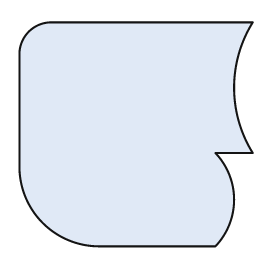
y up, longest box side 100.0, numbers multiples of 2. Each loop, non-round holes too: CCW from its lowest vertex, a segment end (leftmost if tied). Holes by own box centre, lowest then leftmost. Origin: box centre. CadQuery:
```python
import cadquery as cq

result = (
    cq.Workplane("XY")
    .moveTo(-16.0, -48.0)
    .lineTo(34.0, -48.0)
    .threePointArc((42.0, -28.0), (34.0, -8.0))
    .lineTo(50.0, -8.0)
    .threePointArc((42.0, 20.0), (50.0, 48.0))
    .lineTo(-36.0, 48.0)
    .threePointArc((-46.0, 44.0), (-50.0, 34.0))
    .lineTo(-50.0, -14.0)
    .threePointArc((-40.0, -38.0), (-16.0, -48.0))
    .close()
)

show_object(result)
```